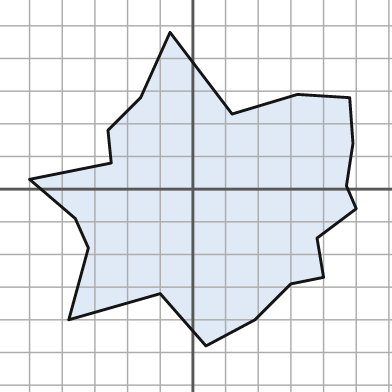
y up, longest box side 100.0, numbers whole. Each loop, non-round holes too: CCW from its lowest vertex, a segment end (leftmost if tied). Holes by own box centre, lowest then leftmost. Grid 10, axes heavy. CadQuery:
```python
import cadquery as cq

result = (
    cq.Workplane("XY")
    .moveTo(4.0, -48.0)
    .lineTo(19.0, -40.0)
    .lineTo(30.0, -29.0)
    .lineTo(40.0, -27.0)
    .lineTo(38.0, -15.0)
    .lineTo(50.0, -6.0)
    .lineTo(47.0, 1.0)
    .lineTo(49.0, 14.0)
    .lineTo(48.0, 28.0)
    .lineTo(32.0, 29.0)
    .lineTo(12.0, 23.0)
    .lineTo(-7.0, 48.0)
    .lineTo(-16.0, 28.0)
    .lineTo(-26.0, 18.0)
    .lineTo(-25.0, 8.0)
    .lineTo(-50.0, 3.0)
    .lineTo(-36.0, -9.0)
    .lineTo(-32.0, -18.0)
    .lineTo(-38.0, -40.0)
    .lineTo(-10.0, -32.0)
    .close()
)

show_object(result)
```